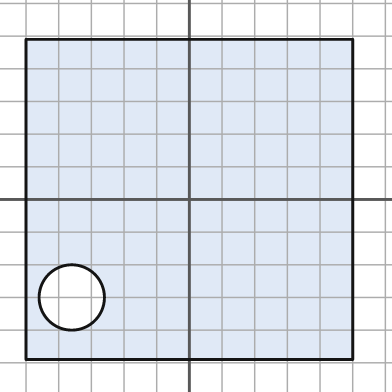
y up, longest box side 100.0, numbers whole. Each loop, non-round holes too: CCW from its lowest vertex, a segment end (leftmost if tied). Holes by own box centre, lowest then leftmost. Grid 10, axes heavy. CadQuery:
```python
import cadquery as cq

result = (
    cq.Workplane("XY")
    .moveTo(-50.0, -49.0)
    .lineTo(50.0, -49.0)
    .lineTo(50.0, 49.0)
    .lineTo(-50.0, 49.0)
    .close()
    .moveTo(-36.0, -30.0)
    .circle(10.0)
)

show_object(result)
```